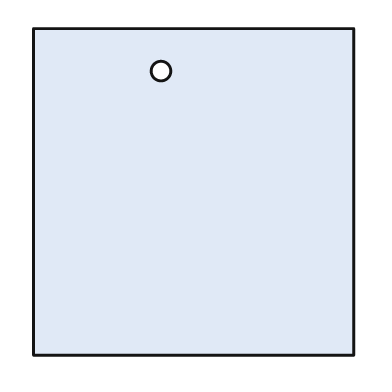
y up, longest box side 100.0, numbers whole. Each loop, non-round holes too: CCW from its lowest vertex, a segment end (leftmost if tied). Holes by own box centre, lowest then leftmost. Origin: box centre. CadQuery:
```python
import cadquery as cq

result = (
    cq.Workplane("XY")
    .moveTo(-49.0, -50.0)
    .lineTo(49.0, -50.0)
    .lineTo(49.0, 50.0)
    .lineTo(-49.0, 50.0)
    .close()
    .moveTo(-10.0, 37.0)
    .circle(3.0)
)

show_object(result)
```